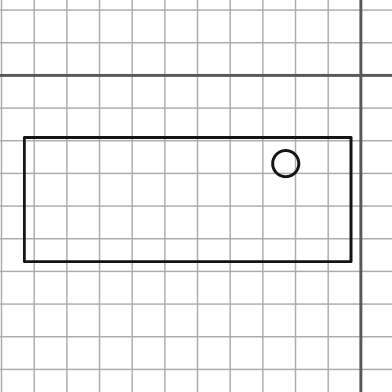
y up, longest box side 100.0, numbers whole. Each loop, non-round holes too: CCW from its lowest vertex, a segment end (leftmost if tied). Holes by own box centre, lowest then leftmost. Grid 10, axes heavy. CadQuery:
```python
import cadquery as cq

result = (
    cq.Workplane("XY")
    .moveTo(-103.0, -57.0)
    .lineTo(-3.0, -57.0)
    .lineTo(-3.0, -19.0)
    .lineTo(-103.0, -19.0)
    .close()
    .moveTo(-23.0, -27.0)
    .circle(4.0)
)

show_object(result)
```